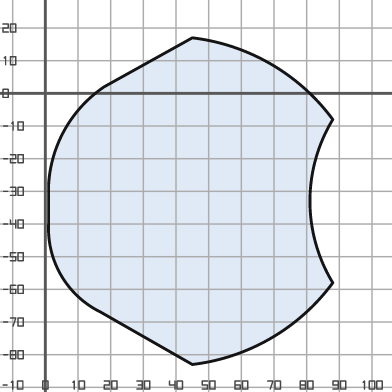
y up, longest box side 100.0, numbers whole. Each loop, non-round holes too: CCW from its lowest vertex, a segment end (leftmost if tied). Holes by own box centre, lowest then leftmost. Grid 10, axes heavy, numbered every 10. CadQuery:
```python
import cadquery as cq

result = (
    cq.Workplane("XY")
    .moveTo(45.0, -83.0)
    .threePointArc((69.0, -75.0), (88.0, -58.0))
    .threePointArc((81.0, -33.0), (88.0, -8.0))
    .threePointArc((69.0, 9.0), (45.0, 17.0))
    .lineTo(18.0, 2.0)
    .threePointArc((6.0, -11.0), (1.0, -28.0))
    .lineTo(1.0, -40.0)
    .threePointArc((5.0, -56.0), (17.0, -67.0))
    .close()
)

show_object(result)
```